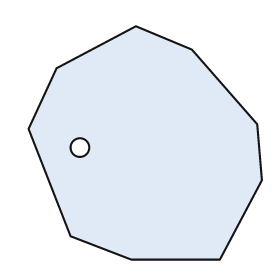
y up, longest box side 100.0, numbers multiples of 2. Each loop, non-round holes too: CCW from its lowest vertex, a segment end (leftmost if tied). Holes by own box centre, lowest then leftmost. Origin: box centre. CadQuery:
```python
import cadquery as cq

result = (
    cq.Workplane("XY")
    .moveTo(-6.0, -50.0)
    .lineTo(32.0, -50.0)
    .lineTo(50.0, -16.0)
    .lineTo(48.0, 8.0)
    .lineTo(20.0, 40.0)
    .lineTo(-4.0, 50.0)
    .lineTo(-38.0, 32.0)
    .lineTo(-50.0, 6.0)
    .lineTo(-32.0, -40.0)
    .close()
    .moveTo(-28.0, -2.0)
    .circle(4.0)
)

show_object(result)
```